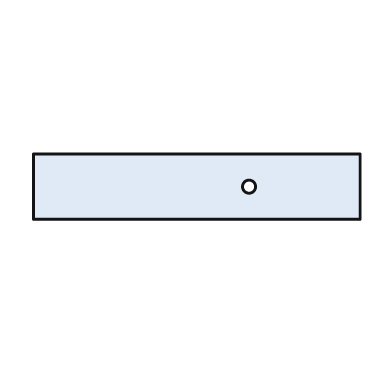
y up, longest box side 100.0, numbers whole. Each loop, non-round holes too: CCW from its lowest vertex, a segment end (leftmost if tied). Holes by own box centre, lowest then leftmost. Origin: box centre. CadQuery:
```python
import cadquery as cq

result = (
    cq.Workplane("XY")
    .moveTo(-50.0, -10.0)
    .lineTo(50.0, -10.0)
    .lineTo(50.0, 10.0)
    .lineTo(-50.0, 10.0)
    .close()
    .moveTo(16.0, 0.0)
    .circle(2.0)
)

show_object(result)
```